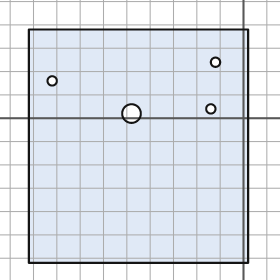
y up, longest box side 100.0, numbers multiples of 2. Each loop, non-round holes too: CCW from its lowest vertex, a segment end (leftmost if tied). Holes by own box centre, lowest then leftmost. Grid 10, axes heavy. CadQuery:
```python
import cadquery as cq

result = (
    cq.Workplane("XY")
    .moveTo(-92.0, -62.0)
    .lineTo(2.0, -62.0)
    .lineTo(2.0, 38.0)
    .lineTo(-92.0, 38.0)
    .close()
    .moveTo(-48.0, 2.0)
    .circle(4.0)
    .moveTo(-14.0, 4.0)
    .circle(2.0)
    .moveTo(-82.0, 16.0)
    .circle(2.0)
    .moveTo(-12.0, 24.0)
    .circle(2.0)
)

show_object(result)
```